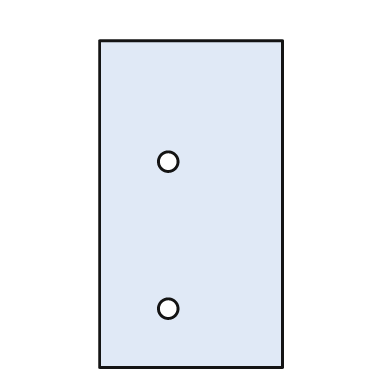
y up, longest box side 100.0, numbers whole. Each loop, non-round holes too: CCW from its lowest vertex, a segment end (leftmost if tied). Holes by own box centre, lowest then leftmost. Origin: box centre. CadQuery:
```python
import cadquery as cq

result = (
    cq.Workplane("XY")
    .moveTo(-28.0, -50.0)
    .lineTo(28.0, -50.0)
    .lineTo(28.0, 50.0)
    .lineTo(-28.0, 50.0)
    .close()
    .moveTo(-7.0, -32.0)
    .circle(3.0)
    .moveTo(-7.0, 13.0)
    .circle(3.0)
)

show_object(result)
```